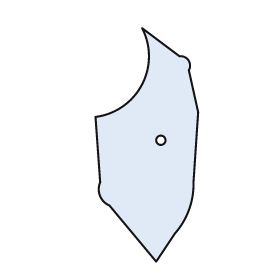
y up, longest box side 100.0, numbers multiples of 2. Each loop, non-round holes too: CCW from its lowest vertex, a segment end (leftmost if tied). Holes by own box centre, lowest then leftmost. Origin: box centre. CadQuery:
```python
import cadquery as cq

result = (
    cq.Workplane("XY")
    .moveTo(4.0, -50.0)
    .lineTo(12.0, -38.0)
    .threePointArc((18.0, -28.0), (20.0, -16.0))
    .lineTo(22.0, 14.0)
    .lineTo(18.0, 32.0)
    .threePointArc((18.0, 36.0), (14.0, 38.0))
    .lineTo(-2.0, 50.0)
    .threePointArc((-2.0, 26.0), (-22.0, 12.0))
    .lineTo(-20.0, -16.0)
    .threePointArc((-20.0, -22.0), (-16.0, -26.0))
    .close()
    .moveTo(6.0, 2.0)
    .circle(2.0)
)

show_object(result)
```